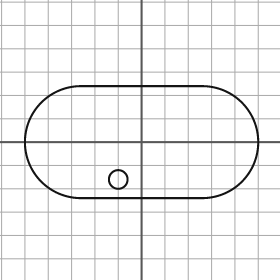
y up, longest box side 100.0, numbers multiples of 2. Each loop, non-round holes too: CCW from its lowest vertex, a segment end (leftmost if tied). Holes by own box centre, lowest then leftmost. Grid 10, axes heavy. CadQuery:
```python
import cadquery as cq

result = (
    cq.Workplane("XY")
    .moveTo(-26.0, -24.0)
    .lineTo(26.0, -24.0)
    .threePointArc((50.0, 0.0), (26.0, 24.0))
    .lineTo(-26.0, 24.0)
    .threePointArc((-50.0, 0.0), (-26.0, -24.0))
    .close()
    .moveTo(-10.0, -16.0)
    .circle(4.0)
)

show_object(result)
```